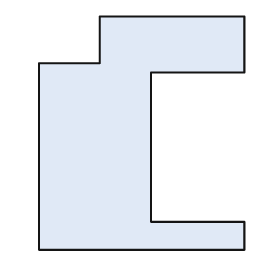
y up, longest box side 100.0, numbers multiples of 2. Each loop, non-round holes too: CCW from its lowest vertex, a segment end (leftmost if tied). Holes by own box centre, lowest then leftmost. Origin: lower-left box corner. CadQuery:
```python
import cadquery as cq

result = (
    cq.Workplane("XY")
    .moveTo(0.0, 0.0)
    .lineTo(88.0, 0.0)
    .lineTo(88.0, 12.0)
    .lineTo(48.0, 12.0)
    .lineTo(48.0, 76.0)
    .lineTo(88.0, 76.0)
    .lineTo(88.0, 100.0)
    .lineTo(26.0, 100.0)
    .lineTo(26.0, 80.0)
    .lineTo(0.0, 80.0)
    .close()
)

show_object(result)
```